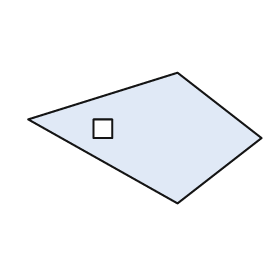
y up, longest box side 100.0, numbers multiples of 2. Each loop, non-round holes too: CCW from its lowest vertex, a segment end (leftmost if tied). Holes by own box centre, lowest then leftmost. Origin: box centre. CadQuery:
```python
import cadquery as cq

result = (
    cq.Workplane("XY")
    .moveTo(14.0, -28.0)
    .lineTo(50.0, 0.0)
    .lineTo(14.0, 28.0)
    .lineTo(-50.0, 8.0)
    .close()
    .moveTo(-22.0, 0.0)
    .lineTo(-14.0, 0.0)
    .lineTo(-14.0, 8.0)
    .lineTo(-22.0, 8.0)
    .close()
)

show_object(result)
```